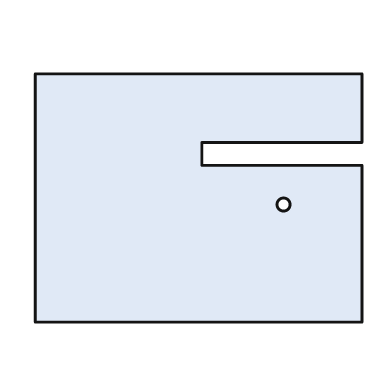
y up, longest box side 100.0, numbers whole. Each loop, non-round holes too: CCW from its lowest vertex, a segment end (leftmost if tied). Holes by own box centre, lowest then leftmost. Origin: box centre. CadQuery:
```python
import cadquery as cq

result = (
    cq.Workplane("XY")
    .moveTo(-50.0, -38.0)
    .lineTo(50.0, -38.0)
    .lineTo(50.0, 10.0)
    .lineTo(1.0, 10.0)
    .lineTo(1.0, 17.0)
    .lineTo(50.0, 17.0)
    .lineTo(50.0, 38.0)
    .lineTo(-50.0, 38.0)
    .close()
    .moveTo(26.0, -2.0)
    .circle(2.0)
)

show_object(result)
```